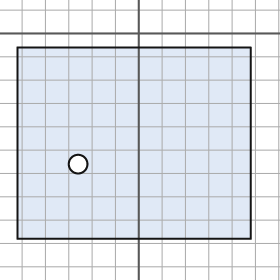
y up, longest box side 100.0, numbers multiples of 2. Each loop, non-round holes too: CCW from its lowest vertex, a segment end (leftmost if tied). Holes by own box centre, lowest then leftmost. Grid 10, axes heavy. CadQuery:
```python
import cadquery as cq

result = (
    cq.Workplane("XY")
    .moveTo(-52.0, -88.0)
    .lineTo(48.0, -88.0)
    .lineTo(48.0, -6.0)
    .lineTo(-52.0, -6.0)
    .close()
    .moveTo(-26.0, -56.0)
    .circle(4.0)
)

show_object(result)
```